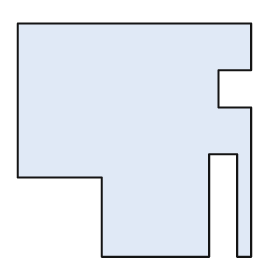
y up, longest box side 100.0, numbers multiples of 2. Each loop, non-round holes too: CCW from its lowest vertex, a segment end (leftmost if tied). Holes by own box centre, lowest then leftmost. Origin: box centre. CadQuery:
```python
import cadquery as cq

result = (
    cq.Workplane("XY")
    .moveTo(-14.0, -50.0)
    .lineTo(32.0, -50.0)
    .lineTo(32.0, -6.0)
    .lineTo(44.0, -6.0)
    .lineTo(44.0, -50.0)
    .lineTo(50.0, -50.0)
    .lineTo(50.0, 14.0)
    .lineTo(36.0, 14.0)
    .lineTo(36.0, 30.0)
    .lineTo(50.0, 30.0)
    .lineTo(50.0, 50.0)
    .lineTo(-50.0, 50.0)
    .lineTo(-50.0, -16.0)
    .lineTo(-14.0, -16.0)
    .close()
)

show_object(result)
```